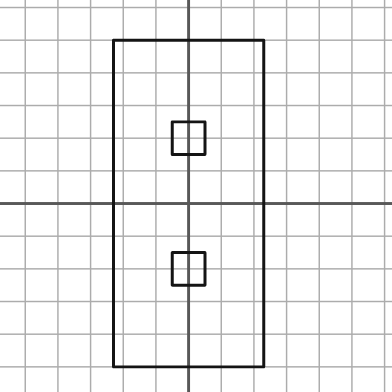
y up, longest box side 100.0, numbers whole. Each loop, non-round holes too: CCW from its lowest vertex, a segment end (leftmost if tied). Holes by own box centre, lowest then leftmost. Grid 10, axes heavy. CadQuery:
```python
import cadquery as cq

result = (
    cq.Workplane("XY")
    .moveTo(-23.0, -50.0)
    .lineTo(23.0, -50.0)
    .lineTo(23.0, 50.0)
    .lineTo(-23.0, 50.0)
    .close()
    .moveTo(-5.0, -25.0)
    .lineTo(5.0, -25.0)
    .lineTo(5.0, -15.0)
    .lineTo(-5.0, -15.0)
    .close()
    .moveTo(-5.0, 15.0)
    .lineTo(5.0, 15.0)
    .lineTo(5.0, 25.0)
    .lineTo(-5.0, 25.0)
    .close()
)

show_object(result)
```